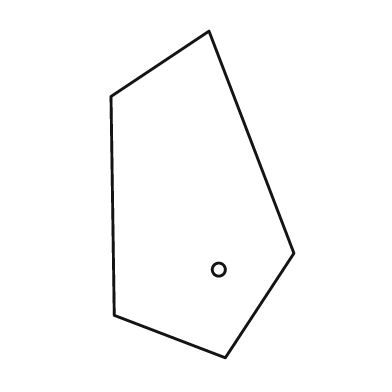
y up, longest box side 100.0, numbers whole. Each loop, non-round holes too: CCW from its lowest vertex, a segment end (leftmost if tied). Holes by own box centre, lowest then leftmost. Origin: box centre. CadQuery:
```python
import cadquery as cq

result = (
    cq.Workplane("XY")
    .moveTo(7.0, -50.0)
    .lineTo(28.0, -18.0)
    .lineTo(2.0, 50.0)
    .lineTo(-28.0, 30.0)
    .lineTo(-27.0, -37.0)
    .close()
    .moveTo(5.0, -23.0)
    .circle(2.0)
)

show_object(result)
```